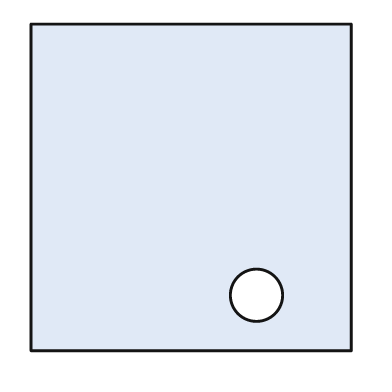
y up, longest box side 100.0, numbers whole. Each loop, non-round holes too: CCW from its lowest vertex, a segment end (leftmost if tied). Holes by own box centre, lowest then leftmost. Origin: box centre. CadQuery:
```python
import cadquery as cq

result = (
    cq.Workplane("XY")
    .moveTo(-49.0, -50.0)
    .lineTo(49.0, -50.0)
    .lineTo(49.0, 50.0)
    .lineTo(-49.0, 50.0)
    .close()
    .moveTo(20.0, -33.0)
    .circle(8.0)
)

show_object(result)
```